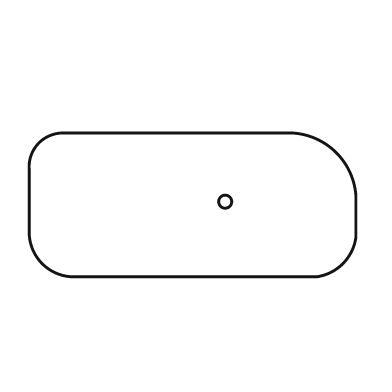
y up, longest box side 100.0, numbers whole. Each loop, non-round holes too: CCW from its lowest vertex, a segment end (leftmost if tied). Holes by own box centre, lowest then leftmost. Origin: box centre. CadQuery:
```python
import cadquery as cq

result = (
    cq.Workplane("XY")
    .moveTo(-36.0, -22.0)
    .lineTo(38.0, -22.0)
    .threePointArc((46.0, -18.0), (50.0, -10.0))
    .lineTo(50.0, 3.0)
    .threePointArc((44.0, 16.0), (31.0, 22.0))
    .lineTo(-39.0, 22.0)
    .threePointArc((-47.0, 19.0), (-50.0, 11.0))
    .lineTo(-50.0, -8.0)
    .threePointArc((-46.0, -18.0), (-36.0, -22.0))
    .close()
    .moveTo(10.0, 1.0)
    .circle(2.0)
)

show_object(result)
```